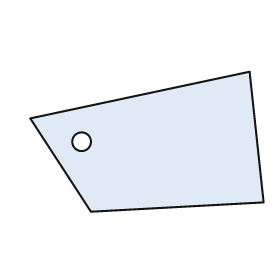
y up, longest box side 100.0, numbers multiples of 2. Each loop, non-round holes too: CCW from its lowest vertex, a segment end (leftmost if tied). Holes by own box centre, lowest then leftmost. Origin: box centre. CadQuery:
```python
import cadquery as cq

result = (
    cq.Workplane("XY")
    .moveTo(-24.0, -30.0)
    .lineTo(50.0, -26.0)
    .lineTo(44.0, 30.0)
    .lineTo(-50.0, 10.0)
    .close()
    .moveTo(-28.0, 0.0)
    .circle(4.0)
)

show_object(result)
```